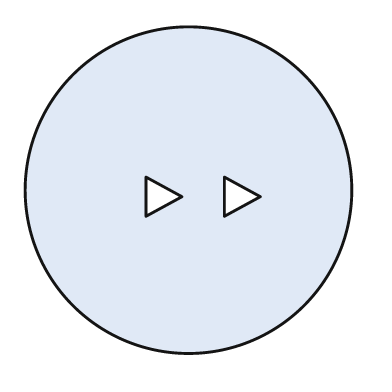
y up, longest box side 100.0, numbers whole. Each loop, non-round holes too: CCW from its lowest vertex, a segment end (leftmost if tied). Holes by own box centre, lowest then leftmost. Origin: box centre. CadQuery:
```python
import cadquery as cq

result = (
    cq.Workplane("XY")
    .moveTo(0.0, 0.0)
    .circle(50.0)
    .moveTo(-13.0, -8.0)
    .lineTo(-2.0, -2.0)
    .lineTo(-13.0, 4.0)
    .close()
    .moveTo(11.0, -8.0)
    .lineTo(22.0, -2.0)
    .lineTo(11.0, 4.0)
    .close()
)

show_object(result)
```